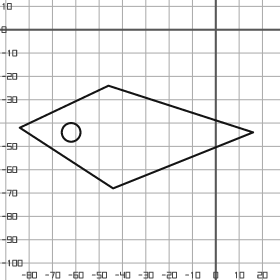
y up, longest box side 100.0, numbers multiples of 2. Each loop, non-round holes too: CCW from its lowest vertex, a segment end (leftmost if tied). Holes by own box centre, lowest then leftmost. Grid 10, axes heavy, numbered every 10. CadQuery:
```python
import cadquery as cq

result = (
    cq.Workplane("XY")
    .moveTo(-44.0, -68.0)
    .lineTo(16.0, -44.0)
    .lineTo(-46.0, -24.0)
    .lineTo(-84.0, -42.0)
    .close()
    .moveTo(-62.0, -44.0)
    .circle(4.0)
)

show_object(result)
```